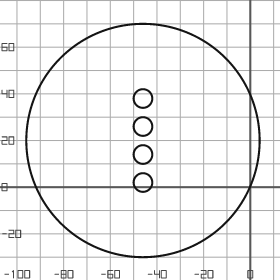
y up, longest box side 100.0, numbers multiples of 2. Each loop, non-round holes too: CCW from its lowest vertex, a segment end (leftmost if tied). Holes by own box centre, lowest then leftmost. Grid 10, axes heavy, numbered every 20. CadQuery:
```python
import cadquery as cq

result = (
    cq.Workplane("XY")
    .moveTo(-46.0, 20.0)
    .circle(50.0)
    .moveTo(-46.0, 2.0)
    .circle(4.0)
    .moveTo(-46.0, 14.0)
    .circle(4.0)
    .moveTo(-46.0, 26.0)
    .circle(4.0)
    .moveTo(-46.0, 38.0)
    .circle(4.0)
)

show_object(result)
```